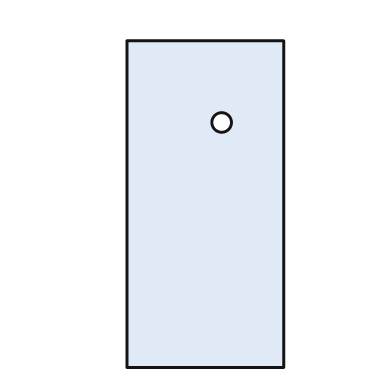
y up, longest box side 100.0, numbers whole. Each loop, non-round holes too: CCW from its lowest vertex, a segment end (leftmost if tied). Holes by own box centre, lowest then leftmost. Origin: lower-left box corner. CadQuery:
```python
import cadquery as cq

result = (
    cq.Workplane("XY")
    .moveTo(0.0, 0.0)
    .lineTo(48.0, 0.0)
    .lineTo(48.0, 100.0)
    .lineTo(0.0, 100.0)
    .close()
    .moveTo(29.0, 75.0)
    .circle(3.0)
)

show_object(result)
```